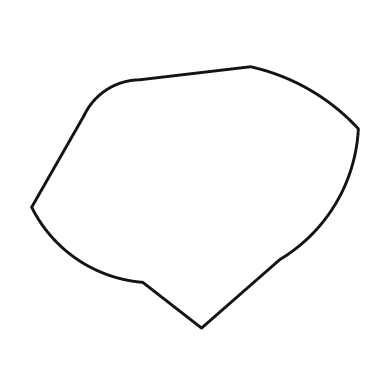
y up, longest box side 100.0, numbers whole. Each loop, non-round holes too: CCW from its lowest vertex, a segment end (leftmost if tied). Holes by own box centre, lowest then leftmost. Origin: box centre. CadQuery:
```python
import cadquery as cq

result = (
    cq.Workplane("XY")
    .moveTo(2.0, -40.0)
    .lineTo(26.0, -19.0)
    .threePointArc((43.0, -2.0), (50.0, 21.0))
    .threePointArc((35.0, 33.0), (17.0, 40.0))
    .lineTo(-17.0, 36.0)
    .threePointArc((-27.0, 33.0), (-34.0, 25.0))
    .lineTo(-50.0, -3.0)
    .threePointArc((-36.0, -19.0), (-16.0, -26.0))
    .close()
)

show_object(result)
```